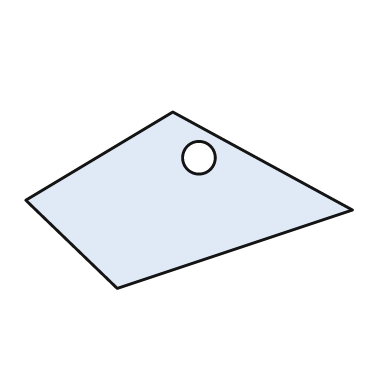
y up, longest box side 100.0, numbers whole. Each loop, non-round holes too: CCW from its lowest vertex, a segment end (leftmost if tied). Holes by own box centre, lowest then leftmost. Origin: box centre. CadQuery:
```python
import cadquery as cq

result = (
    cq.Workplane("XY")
    .moveTo(-22.0, -27.0)
    .lineTo(50.0, -3.0)
    .lineTo(-5.0, 27.0)
    .lineTo(-50.0, 0.0)
    .close()
    .moveTo(3.0, 13.0)
    .circle(5.0)
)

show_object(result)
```